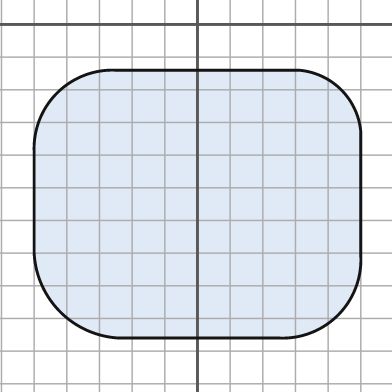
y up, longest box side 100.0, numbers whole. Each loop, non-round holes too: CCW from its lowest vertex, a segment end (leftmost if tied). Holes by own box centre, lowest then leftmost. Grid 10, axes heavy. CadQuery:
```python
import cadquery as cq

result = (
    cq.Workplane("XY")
    .moveTo(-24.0, -96.0)
    .lineTo(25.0, -96.0)
    .threePointArc((43.0, -89.0), (50.0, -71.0))
    .lineTo(50.0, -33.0)
    .threePointArc((44.0, -20.0), (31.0, -14.0))
    .lineTo(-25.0, -14.0)
    .threePointArc((-43.0, -21.0), (-50.0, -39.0))
    .lineTo(-50.0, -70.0)
    .threePointArc((-42.0, -88.0), (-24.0, -96.0))
    .close()
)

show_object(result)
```